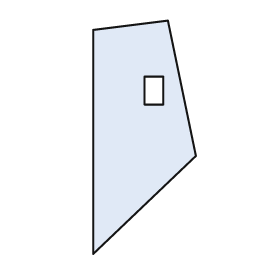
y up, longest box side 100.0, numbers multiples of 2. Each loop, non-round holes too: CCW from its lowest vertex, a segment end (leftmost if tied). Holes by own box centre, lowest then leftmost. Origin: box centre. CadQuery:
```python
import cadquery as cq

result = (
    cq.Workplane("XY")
    .moveTo(-22.0, -50.0)
    .lineTo(22.0, -8.0)
    .lineTo(10.0, 50.0)
    .lineTo(-22.0, 46.0)
    .close()
    .moveTo(0.0, 14.0)
    .lineTo(8.0, 14.0)
    .lineTo(8.0, 26.0)
    .lineTo(0.0, 26.0)
    .close()
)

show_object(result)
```